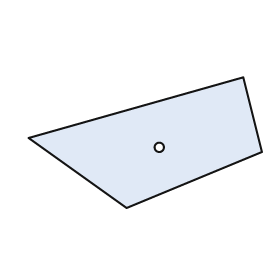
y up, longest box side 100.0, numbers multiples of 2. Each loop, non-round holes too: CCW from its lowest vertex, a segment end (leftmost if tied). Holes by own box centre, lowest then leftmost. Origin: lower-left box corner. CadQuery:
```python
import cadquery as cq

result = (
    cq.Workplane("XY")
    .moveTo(42.0, 0.0)
    .lineTo(100.0, 24.0)
    .lineTo(92.0, 56.0)
    .lineTo(0.0, 30.0)
    .close()
    .moveTo(56.0, 26.0)
    .circle(2.0)
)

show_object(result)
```